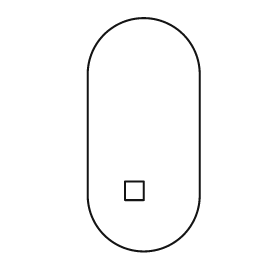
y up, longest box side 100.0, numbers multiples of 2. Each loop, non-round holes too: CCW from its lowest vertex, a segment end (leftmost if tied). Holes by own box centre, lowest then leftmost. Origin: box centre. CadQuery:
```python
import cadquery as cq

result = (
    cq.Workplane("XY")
    .moveTo(-24.0, -26.0)
    .threePointArc((0.0, -50.0), (24.0, -26.0))
    .lineTo(24.0, 26.0)
    .threePointArc((0.0, 50.0), (-24.0, 26.0))
    .close()
    .moveTo(-8.0, -28.0)
    .lineTo(0.0, -28.0)
    .lineTo(0.0, -20.0)
    .lineTo(-8.0, -20.0)
    .close()
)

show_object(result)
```